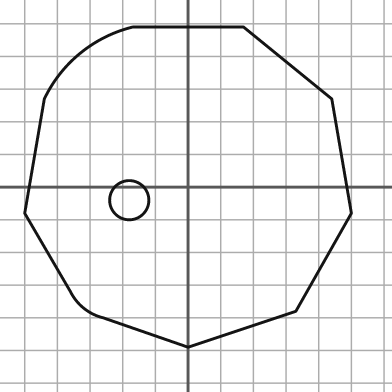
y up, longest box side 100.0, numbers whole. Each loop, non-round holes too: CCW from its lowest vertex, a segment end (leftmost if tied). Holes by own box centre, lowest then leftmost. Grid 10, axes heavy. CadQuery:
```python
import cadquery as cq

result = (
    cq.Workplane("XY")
    .moveTo(0.0, -49.0)
    .lineTo(33.0, -38.0)
    .lineTo(50.0, -8.0)
    .lineTo(44.0, 27.0)
    .lineTo(17.0, 49.0)
    .lineTo(-17.0, 49.0)
    .threePointArc((-33.0, 41.0), (-44.0, 27.0))
    .lineTo(-50.0, -8.0)
    .lineTo(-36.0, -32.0)
    .threePointArc((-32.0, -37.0), (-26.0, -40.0))
    .close()
    .moveTo(-18.0, -4.0)
    .circle(6.0)
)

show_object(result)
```